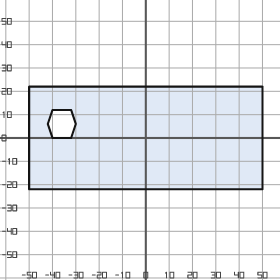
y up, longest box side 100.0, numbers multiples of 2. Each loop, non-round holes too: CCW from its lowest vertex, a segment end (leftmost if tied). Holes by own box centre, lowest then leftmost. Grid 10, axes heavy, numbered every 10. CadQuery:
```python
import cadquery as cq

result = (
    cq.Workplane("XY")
    .moveTo(-50.0, -22.0)
    .lineTo(50.0, -22.0)
    .lineTo(50.0, 22.0)
    .lineTo(-50.0, 22.0)
    .close()
    .moveTo(-40.0, 0.0)
    .lineTo(-32.0, 0.0)
    .lineTo(-30.0, 6.0)
    .lineTo(-32.0, 12.0)
    .lineTo(-40.0, 12.0)
    .lineTo(-42.0, 6.0)
    .close()
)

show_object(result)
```